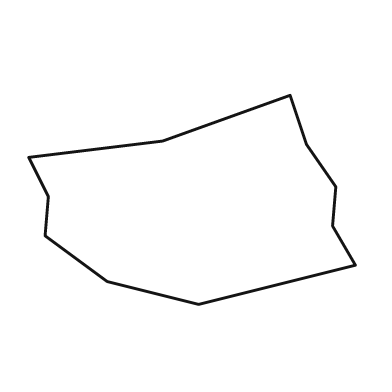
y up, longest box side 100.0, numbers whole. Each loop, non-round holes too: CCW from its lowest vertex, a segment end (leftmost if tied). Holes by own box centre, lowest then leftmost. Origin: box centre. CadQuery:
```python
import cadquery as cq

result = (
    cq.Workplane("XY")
    .moveTo(2.0, -32.0)
    .lineTo(50.0, -20.0)
    .lineTo(43.0, -8.0)
    .lineTo(44.0, 4.0)
    .lineTo(35.0, 17.0)
    .lineTo(30.0, 32.0)
    .lineTo(-9.0, 18.0)
    .lineTo(-50.0, 13.0)
    .lineTo(-44.0, 1.0)
    .lineTo(-45.0, -11.0)
    .lineTo(-26.0, -25.0)
    .close()
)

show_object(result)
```